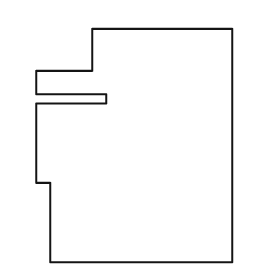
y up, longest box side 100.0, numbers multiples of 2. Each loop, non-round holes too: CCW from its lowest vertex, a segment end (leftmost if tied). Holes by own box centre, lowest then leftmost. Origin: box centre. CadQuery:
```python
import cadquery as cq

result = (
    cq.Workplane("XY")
    .moveTo(-36.0, -50.0)
    .lineTo(42.0, -50.0)
    .lineTo(42.0, 50.0)
    .lineTo(-18.0, 50.0)
    .lineTo(-18.0, 32.0)
    .lineTo(-42.0, 32.0)
    .lineTo(-42.0, 22.0)
    .lineTo(-12.0, 22.0)
    .lineTo(-12.0, 18.0)
    .lineTo(-42.0, 18.0)
    .lineTo(-42.0, -16.0)
    .lineTo(-36.0, -16.0)
    .close()
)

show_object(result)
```